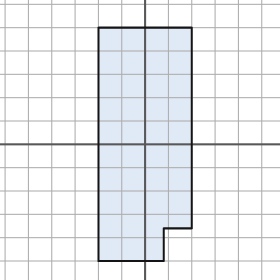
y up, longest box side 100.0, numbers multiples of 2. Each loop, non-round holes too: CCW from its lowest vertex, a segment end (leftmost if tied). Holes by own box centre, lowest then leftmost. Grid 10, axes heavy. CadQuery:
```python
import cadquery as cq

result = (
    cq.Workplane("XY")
    .moveTo(-20.0, -50.0)
    .lineTo(8.0, -50.0)
    .lineTo(8.0, -36.0)
    .lineTo(20.0, -36.0)
    .lineTo(20.0, 50.0)
    .lineTo(-20.0, 50.0)
    .close()
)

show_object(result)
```